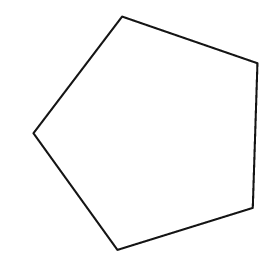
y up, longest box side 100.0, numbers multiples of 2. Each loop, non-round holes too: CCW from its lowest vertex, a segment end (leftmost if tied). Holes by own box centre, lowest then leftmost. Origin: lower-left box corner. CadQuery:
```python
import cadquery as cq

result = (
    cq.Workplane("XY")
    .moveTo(36.0, 0.0)
    .lineTo(94.0, 18.0)
    .lineTo(96.0, 80.0)
    .lineTo(38.0, 100.0)
    .lineTo(0.0, 50.0)
    .close()
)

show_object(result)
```